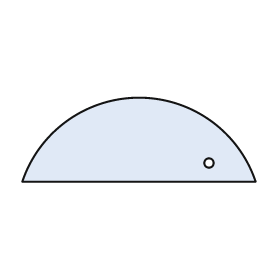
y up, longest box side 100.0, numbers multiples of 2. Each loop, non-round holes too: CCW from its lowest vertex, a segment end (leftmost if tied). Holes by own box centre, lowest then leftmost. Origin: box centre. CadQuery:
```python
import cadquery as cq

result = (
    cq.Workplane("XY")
    .moveTo(-50.0, -18.0)
    .lineTo(50.0, -18.0)
    .threePointArc((0.0, 18.0), (-50.0, -18.0))
    .close()
    .moveTo(30.0, -10.0)
    .circle(2.0)
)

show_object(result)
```